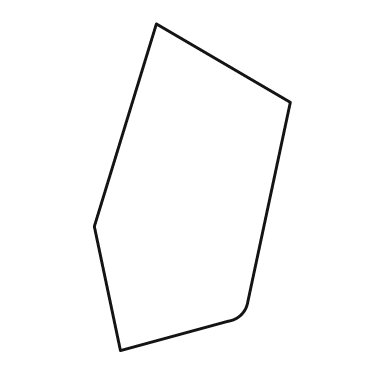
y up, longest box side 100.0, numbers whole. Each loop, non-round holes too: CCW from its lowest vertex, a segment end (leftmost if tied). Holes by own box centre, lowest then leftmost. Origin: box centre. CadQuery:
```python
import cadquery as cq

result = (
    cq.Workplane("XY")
    .moveTo(-22.0, -50.0)
    .lineTo(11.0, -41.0)
    .threePointArc((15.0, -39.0), (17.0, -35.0))
    .lineTo(30.0, 26.0)
    .lineTo(-11.0, 50.0)
    .lineTo(-30.0, -12.0)
    .close()
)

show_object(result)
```